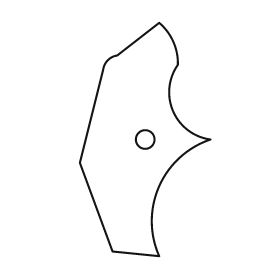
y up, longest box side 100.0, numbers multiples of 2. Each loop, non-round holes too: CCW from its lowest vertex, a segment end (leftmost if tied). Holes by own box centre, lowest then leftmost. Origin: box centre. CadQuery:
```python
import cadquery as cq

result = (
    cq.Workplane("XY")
    .moveTo(6.0, -50.0)
    .threePointArc((6.0, -20.0), (28.0, 0.0))
    .threePointArc((12.0, 12.0), (14.0, 32.0))
    .threePointArc((12.0, 42.0), (6.0, 50.0))
    .lineTo(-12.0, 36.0)
    .threePointArc((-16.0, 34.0), (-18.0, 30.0))
    .lineTo(-28.0, -10.0)
    .lineTo(-14.0, -48.0)
    .close()
    .moveTo(0.0, 0.0)
    .circle(4.0)
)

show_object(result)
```